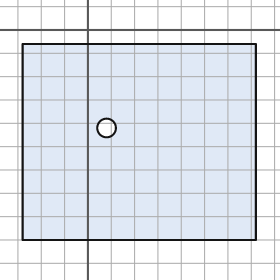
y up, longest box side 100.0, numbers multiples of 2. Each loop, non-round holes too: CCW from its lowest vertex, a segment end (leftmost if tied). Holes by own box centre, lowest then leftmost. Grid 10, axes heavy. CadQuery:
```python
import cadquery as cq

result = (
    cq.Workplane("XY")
    .moveTo(-28.0, -90.0)
    .lineTo(72.0, -90.0)
    .lineTo(72.0, -6.0)
    .lineTo(-28.0, -6.0)
    .close()
    .moveTo(8.0, -42.0)
    .circle(4.0)
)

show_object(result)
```